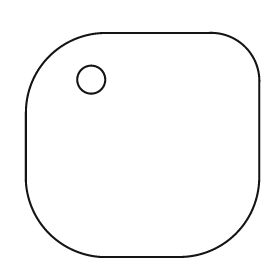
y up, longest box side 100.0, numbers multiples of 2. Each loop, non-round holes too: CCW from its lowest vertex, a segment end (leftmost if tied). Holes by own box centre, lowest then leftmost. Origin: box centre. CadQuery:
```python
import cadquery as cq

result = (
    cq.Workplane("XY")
    .moveTo(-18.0, -48.0)
    .lineTo(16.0, -48.0)
    .threePointArc((40.0, -38.0), (50.0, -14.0))
    .lineTo(50.0, 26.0)
    .threePointArc((44.0, 42.0), (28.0, 48.0))
    .lineTo(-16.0, 48.0)
    .threePointArc((-40.0, 38.0), (-50.0, 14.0))
    .lineTo(-50.0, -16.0)
    .threePointArc((-40.0, -38.0), (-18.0, -48.0))
    .close()
    .moveTo(-22.0, 28.0)
    .circle(6.0)
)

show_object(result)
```